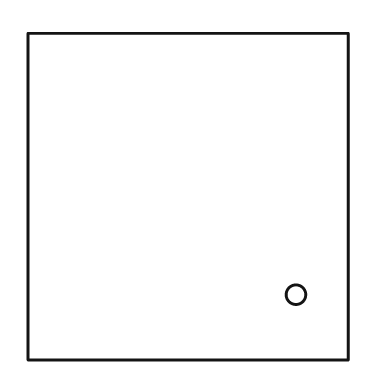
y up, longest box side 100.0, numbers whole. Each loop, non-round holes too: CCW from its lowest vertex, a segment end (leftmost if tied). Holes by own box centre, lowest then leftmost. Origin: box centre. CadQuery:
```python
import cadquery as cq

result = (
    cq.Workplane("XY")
    .moveTo(-49.0, -50.0)
    .lineTo(49.0, -50.0)
    .lineTo(49.0, 50.0)
    .lineTo(-49.0, 50.0)
    .close()
    .moveTo(33.0, -30.0)
    .circle(3.0)
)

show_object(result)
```